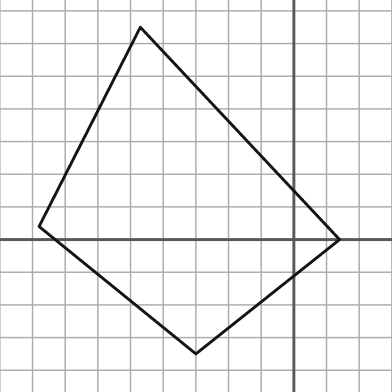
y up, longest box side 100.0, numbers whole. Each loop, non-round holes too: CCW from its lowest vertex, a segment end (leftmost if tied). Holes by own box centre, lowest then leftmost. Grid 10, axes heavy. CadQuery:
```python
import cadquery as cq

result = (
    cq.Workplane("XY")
    .moveTo(-30.0, -35.0)
    .lineTo(14.0, 0.0)
    .lineTo(-47.0, 65.0)
    .lineTo(-78.0, 4.0)
    .close()
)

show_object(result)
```